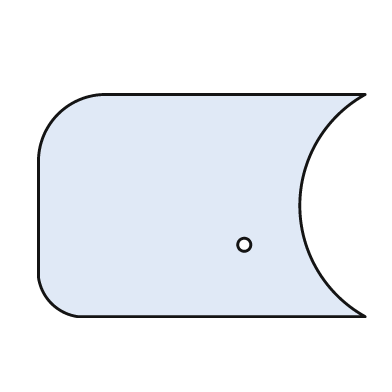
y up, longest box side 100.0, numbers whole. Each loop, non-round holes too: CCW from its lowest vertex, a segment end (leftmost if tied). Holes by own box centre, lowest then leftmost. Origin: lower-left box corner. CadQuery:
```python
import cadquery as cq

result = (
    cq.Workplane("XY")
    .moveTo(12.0, 0.0)
    .lineTo(100.0, 0.0)
    .threePointArc((80.0, 34.0), (100.0, 68.0))
    .lineTo(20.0, 68.0)
    .threePointArc((6.0, 62.0), (0.0, 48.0))
    .lineTo(0.0, 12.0)
    .threePointArc((4.0, 4.0), (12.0, 0.0))
    .close()
    .moveTo(63.0, 22.0)
    .circle(2.0)
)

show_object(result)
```